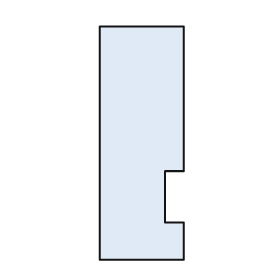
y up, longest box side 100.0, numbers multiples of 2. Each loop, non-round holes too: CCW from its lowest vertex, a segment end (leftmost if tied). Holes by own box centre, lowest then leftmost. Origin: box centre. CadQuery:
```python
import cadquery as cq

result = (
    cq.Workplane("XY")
    .moveTo(-18.0, -50.0)
    .lineTo(18.0, -50.0)
    .lineTo(18.0, -34.0)
    .lineTo(10.0, -34.0)
    .lineTo(10.0, -12.0)
    .lineTo(18.0, -12.0)
    .lineTo(18.0, 50.0)
    .lineTo(-18.0, 50.0)
    .close()
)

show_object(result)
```